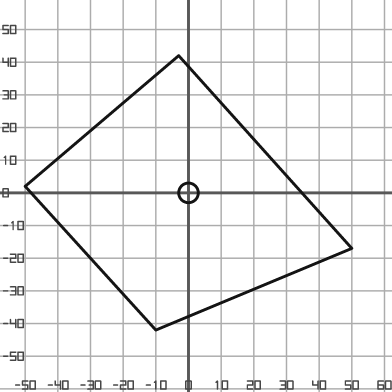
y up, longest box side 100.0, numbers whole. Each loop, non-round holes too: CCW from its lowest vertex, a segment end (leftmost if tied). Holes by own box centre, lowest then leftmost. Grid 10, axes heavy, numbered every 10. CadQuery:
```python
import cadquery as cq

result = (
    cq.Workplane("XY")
    .moveTo(-10.0, -42.0)
    .lineTo(50.0, -17.0)
    .lineTo(-3.0, 42.0)
    .lineTo(-50.0, 2.0)
    .close()
    .moveTo(0.0, 0.0)
    .circle(3.0)
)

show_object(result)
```